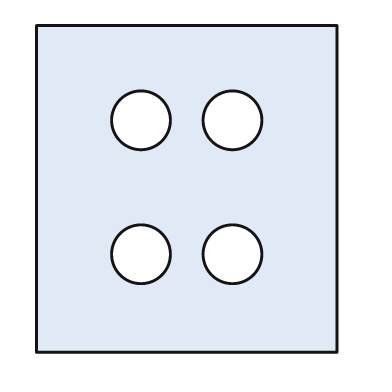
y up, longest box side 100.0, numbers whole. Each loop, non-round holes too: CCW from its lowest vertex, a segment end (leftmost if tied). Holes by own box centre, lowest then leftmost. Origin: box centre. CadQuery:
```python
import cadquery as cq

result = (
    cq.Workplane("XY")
    .moveTo(-46.0, -50.0)
    .lineTo(46.0, -50.0)
    .lineTo(46.0, 50.0)
    .lineTo(-46.0, 50.0)
    .close()
    .moveTo(-14.0, -20.0)
    .circle(9.0)
    .moveTo(14.0, -20.0)
    .circle(9.0)
    .moveTo(-14.0, 21.0)
    .circle(9.0)
    .moveTo(14.0, 21.0)
    .circle(9.0)
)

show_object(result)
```